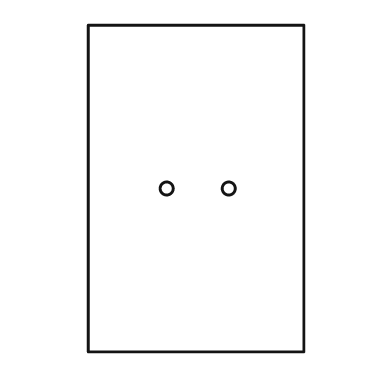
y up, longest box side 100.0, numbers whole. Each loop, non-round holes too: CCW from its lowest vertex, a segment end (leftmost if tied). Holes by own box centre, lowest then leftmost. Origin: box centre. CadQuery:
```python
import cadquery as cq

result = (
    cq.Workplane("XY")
    .moveTo(-33.0, -50.0)
    .lineTo(33.0, -50.0)
    .lineTo(33.0, 50.0)
    .lineTo(-33.0, 50.0)
    .close()
    .moveTo(-9.0, 0.0)
    .circle(2.0)
    .moveTo(10.0, 0.0)
    .circle(2.0)
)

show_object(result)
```